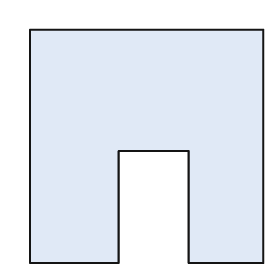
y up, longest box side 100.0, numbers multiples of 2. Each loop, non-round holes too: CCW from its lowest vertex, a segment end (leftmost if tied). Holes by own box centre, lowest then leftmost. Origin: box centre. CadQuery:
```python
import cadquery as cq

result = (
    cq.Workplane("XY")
    .moveTo(-50.0, -50.0)
    .lineTo(-12.0, -50.0)
    .lineTo(-12.0, -2.0)
    .lineTo(18.0, -2.0)
    .lineTo(18.0, -50.0)
    .lineTo(50.0, -50.0)
    .lineTo(50.0, 50.0)
    .lineTo(-50.0, 50.0)
    .close()
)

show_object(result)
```